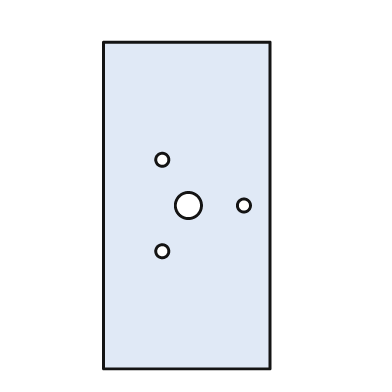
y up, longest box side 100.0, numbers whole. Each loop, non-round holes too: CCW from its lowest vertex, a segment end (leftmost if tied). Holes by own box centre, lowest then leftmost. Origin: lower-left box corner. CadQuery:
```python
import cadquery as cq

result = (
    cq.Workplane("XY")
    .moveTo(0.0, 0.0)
    .lineTo(51.0, 0.0)
    .lineTo(51.0, 100.0)
    .lineTo(0.0, 100.0)
    .close()
    .moveTo(18.0, 36.0)
    .circle(2.0)
    .moveTo(26.0, 50.0)
    .circle(4.0)
    .moveTo(43.0, 50.0)
    .circle(2.0)
    .moveTo(18.0, 64.0)
    .circle(2.0)
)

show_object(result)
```